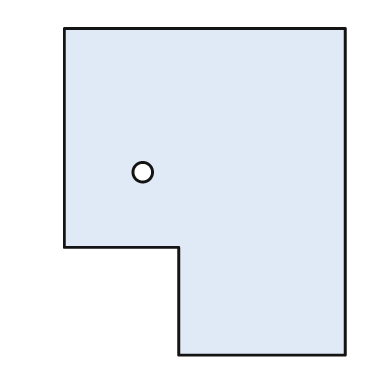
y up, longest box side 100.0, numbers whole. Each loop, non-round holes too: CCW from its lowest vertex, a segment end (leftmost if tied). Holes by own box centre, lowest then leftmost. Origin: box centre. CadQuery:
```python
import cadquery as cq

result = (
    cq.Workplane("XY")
    .moveTo(-8.0, -50.0)
    .lineTo(43.0, -50.0)
    .lineTo(43.0, 50.0)
    .lineTo(-43.0, 50.0)
    .lineTo(-43.0, -17.0)
    .lineTo(-8.0, -17.0)
    .close()
    .moveTo(-19.0, 6.0)
    .circle(3.0)
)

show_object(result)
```